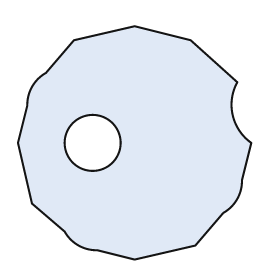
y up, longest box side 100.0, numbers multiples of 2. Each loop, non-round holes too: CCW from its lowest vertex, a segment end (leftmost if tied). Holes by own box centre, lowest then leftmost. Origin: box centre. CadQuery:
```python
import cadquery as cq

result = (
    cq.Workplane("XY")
    .moveTo(0.0, -50.0)
    .lineTo(26.0, -44.0)
    .lineTo(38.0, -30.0)
    .threePointArc((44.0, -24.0), (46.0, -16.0))
    .lineTo(50.0, 0.0)
    .threePointArc((42.0, 12.0), (44.0, 26.0))
    .lineTo(24.0, 44.0)
    .lineTo(0.0, 50.0)
    .lineTo(-26.0, 44.0)
    .lineTo(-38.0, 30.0)
    .threePointArc((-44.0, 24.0), (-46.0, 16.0))
    .lineTo(-50.0, 0.0)
    .lineTo(-44.0, -26.0)
    .lineTo(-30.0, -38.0)
    .threePointArc((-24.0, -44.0), (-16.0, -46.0))
    .close()
    .moveTo(-18.0, 0.0)
    .circle(12.0)
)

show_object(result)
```